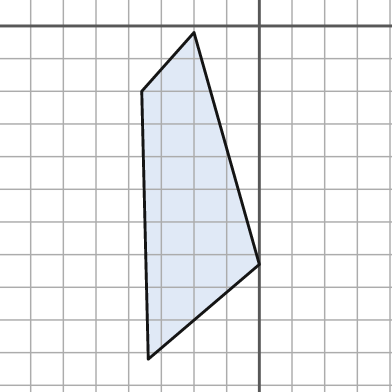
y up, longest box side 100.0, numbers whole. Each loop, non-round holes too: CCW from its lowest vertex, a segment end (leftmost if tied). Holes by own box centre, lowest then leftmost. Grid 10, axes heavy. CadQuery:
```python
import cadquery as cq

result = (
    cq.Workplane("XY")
    .moveTo(-34.0, -102.0)
    .lineTo(0.0, -73.0)
    .lineTo(-20.0, -2.0)
    .lineTo(-36.0, -20.0)
    .close()
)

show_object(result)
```